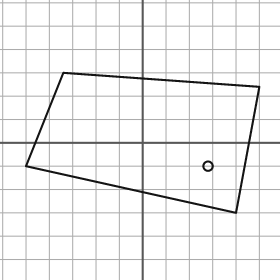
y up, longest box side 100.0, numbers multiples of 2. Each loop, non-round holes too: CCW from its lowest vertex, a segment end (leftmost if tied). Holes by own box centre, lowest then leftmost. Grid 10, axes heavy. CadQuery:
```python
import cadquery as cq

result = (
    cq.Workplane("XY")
    .moveTo(40.0, -30.0)
    .lineTo(50.0, 24.0)
    .lineTo(-34.0, 30.0)
    .lineTo(-50.0, -10.0)
    .close()
    .moveTo(28.0, -10.0)
    .circle(2.0)
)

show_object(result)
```